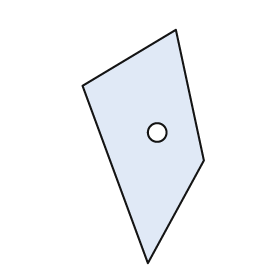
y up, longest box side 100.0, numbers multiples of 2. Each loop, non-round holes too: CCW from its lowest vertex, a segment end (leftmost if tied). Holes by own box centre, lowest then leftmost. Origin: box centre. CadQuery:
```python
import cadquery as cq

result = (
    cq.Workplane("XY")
    .moveTo(2.0, -50.0)
    .lineTo(26.0, -6.0)
    .lineTo(14.0, 50.0)
    .lineTo(-26.0, 26.0)
    .close()
    .moveTo(6.0, 6.0)
    .circle(4.0)
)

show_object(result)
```